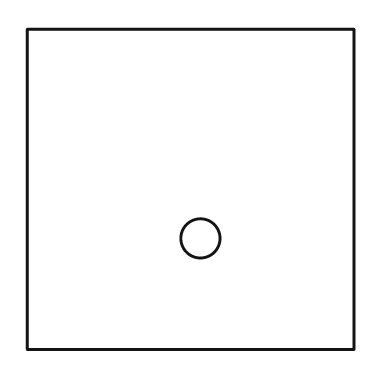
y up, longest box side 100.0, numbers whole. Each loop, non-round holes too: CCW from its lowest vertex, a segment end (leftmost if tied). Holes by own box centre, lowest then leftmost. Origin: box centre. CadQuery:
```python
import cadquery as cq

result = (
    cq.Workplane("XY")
    .moveTo(-50.0, -49.0)
    .lineTo(50.0, -49.0)
    .lineTo(50.0, 49.0)
    .lineTo(-50.0, 49.0)
    .close()
    .moveTo(3.0, -15.0)
    .circle(6.0)
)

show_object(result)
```